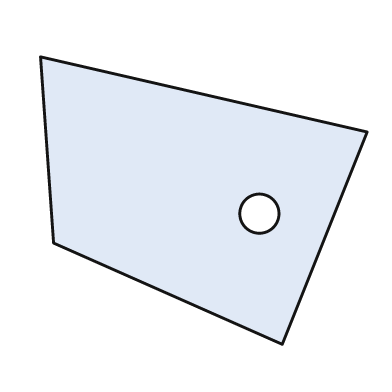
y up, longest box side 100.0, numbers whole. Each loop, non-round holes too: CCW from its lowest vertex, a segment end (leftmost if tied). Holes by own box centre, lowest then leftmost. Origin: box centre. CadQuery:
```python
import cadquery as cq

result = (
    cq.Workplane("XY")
    .moveTo(24.0, -44.0)
    .lineTo(50.0, 21.0)
    .lineTo(-50.0, 44.0)
    .lineTo(-46.0, -13.0)
    .close()
    .moveTo(17.0, -4.0)
    .circle(6.0)
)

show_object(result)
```